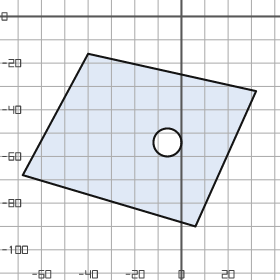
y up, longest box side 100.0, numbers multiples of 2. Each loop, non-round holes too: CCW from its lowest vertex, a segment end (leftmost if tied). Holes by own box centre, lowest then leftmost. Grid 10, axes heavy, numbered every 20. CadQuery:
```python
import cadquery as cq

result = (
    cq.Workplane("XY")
    .moveTo(6.0, -90.0)
    .lineTo(32.0, -32.0)
    .lineTo(-40.0, -16.0)
    .lineTo(-68.0, -68.0)
    .close()
    .moveTo(-6.0, -54.0)
    .circle(6.0)
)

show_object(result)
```